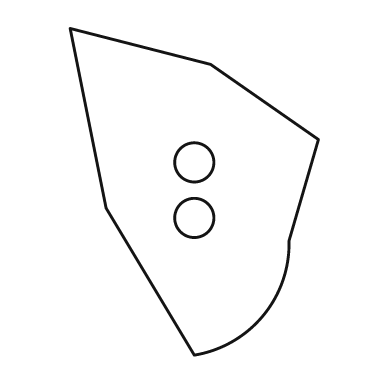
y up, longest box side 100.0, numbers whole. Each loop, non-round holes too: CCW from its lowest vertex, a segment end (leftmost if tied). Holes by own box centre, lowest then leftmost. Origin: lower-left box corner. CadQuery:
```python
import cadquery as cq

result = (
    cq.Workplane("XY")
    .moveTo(38.0, 0.0)
    .threePointArc((59.0, 12.0), (67.0, 35.0))
    .lineTo(76.0, 66.0)
    .lineTo(43.0, 89.0)
    .lineTo(0.0, 100.0)
    .lineTo(11.0, 45.0)
    .close()
    .moveTo(38.0, 42.0)
    .circle(6.0)
    .moveTo(38.0, 59.0)
    .circle(6.0)
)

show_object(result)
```